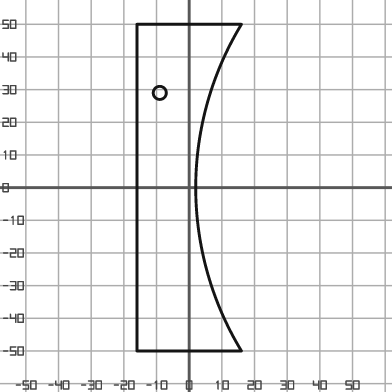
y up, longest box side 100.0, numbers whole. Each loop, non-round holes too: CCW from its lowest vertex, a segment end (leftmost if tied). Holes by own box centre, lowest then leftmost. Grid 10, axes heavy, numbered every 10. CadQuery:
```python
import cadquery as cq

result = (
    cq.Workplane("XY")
    .moveTo(-16.0, -50.0)
    .lineTo(16.0, -50.0)
    .threePointArc((2.0, 0.0), (16.0, 50.0))
    .lineTo(-16.0, 50.0)
    .close()
    .moveTo(-9.0, 29.0)
    .circle(2.0)
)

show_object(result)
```